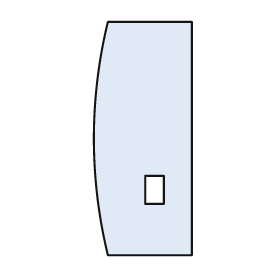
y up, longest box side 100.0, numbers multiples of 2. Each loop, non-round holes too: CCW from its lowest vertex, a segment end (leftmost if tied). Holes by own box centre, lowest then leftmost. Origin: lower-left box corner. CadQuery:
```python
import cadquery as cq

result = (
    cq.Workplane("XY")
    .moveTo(6.0, 0.0)
    .lineTo(42.0, 0.0)
    .lineTo(42.0, 100.0)
    .lineTo(6.0, 100.0)
    .threePointArc((0.0, 50.0), (6.0, 0.0))
    .close()
    .moveTo(22.0, 22.0)
    .lineTo(30.0, 22.0)
    .lineTo(30.0, 34.0)
    .lineTo(22.0, 34.0)
    .close()
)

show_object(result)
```